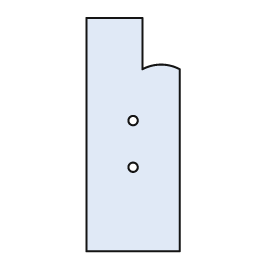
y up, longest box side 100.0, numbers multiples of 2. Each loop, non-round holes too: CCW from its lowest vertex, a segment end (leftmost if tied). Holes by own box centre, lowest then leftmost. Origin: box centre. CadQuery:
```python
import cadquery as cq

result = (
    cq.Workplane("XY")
    .moveTo(-20.0, -50.0)
    .lineTo(20.0, -50.0)
    .lineTo(20.0, 28.0)
    .threePointArc((12.0, 30.0), (4.0, 28.0))
    .lineTo(4.0, 50.0)
    .lineTo(-20.0, 50.0)
    .close()
    .moveTo(0.0, -14.0)
    .circle(2.0)
    .moveTo(0.0, 6.0)
    .circle(2.0)
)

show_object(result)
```